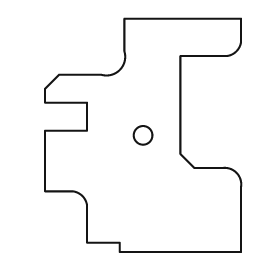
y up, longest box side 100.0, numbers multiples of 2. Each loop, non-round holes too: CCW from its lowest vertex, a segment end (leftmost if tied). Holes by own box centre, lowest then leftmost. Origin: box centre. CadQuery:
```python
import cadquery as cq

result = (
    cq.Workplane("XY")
    .moveTo(-10.0, -50.0)
    .lineTo(42.0, -50.0)
    .lineTo(42.0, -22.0)
    .threePointArc((40.0, -16.0), (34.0, -14.0))
    .lineTo(22.0, -14.0)
    .lineTo(16.0, -8.0)
    .lineTo(16.0, 34.0)
    .lineTo(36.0, 34.0)
    .threePointArc((40.0, 36.0), (42.0, 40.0))
    .lineTo(42.0, 50.0)
    .lineTo(-8.0, 50.0)
    .lineTo(-8.0, 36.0)
    .threePointArc((-10.0, 28.0), (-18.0, 26.0))
    .lineTo(-36.0, 26.0)
    .lineTo(-42.0, 20.0)
    .lineTo(-42.0, 14.0)
    .lineTo(-24.0, 14.0)
    .lineTo(-24.0, 2.0)
    .lineTo(-42.0, 2.0)
    .lineTo(-42.0, -24.0)
    .lineTo(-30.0, -24.0)
    .threePointArc((-26.0, -26.0), (-24.0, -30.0))
    .lineTo(-24.0, -46.0)
    .lineTo(-10.0, -46.0)
    .close()
    .moveTo(0.0, 0.0)
    .circle(4.0)
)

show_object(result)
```